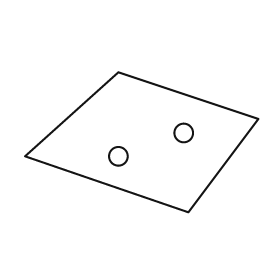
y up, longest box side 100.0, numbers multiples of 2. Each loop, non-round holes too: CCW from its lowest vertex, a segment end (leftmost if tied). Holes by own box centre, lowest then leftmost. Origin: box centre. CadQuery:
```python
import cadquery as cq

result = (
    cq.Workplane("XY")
    .moveTo(20.0, -30.0)
    .lineTo(50.0, 10.0)
    .lineTo(-10.0, 30.0)
    .lineTo(-50.0, -6.0)
    .close()
    .moveTo(-10.0, -6.0)
    .circle(4.0)
    .moveTo(18.0, 4.0)
    .circle(4.0)
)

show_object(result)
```